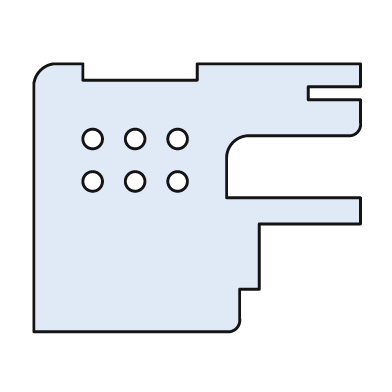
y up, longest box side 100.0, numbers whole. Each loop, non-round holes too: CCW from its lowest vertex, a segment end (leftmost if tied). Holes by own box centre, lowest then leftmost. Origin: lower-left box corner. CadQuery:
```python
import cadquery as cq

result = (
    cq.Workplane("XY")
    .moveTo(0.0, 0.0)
    .lineTo(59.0, 0.0)
    .threePointArc((62.0, 1.0), (63.0, 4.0))
    .lineTo(63.0, 13.0)
    .lineTo(69.0, 13.0)
    .lineTo(69.0, 33.0)
    .lineTo(100.0, 33.0)
    .lineTo(100.0, 41.0)
    .lineTo(59.0, 41.0)
    .lineTo(59.0, 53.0)
    .threePointArc((61.0, 58.0), (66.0, 60.0))
    .lineTo(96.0, 60.0)
    .threePointArc((99.0, 61.0), (100.0, 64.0))
    .lineTo(100.0, 71.0)
    .lineTo(84.0, 71.0)
    .lineTo(84.0, 75.0)
    .lineTo(100.0, 75.0)
    .lineTo(100.0, 82.0)
    .lineTo(50.0, 82.0)
    .lineTo(50.0, 77.0)
    .lineTo(15.0, 77.0)
    .lineTo(15.0, 82.0)
    .lineTo(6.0, 82.0)
    .threePointArc((2.0, 80.0), (0.0, 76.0))
    .close()
    .moveTo(18.0, 46.0)
    .circle(3.0)
    .moveTo(31.0, 46.0)
    .circle(3.0)
    .moveTo(44.0, 46.0)
    .circle(3.0)
    .moveTo(18.0, 59.0)
    .circle(3.0)
    .moveTo(31.0, 59.0)
    .circle(3.0)
    .moveTo(44.0, 59.0)
    .circle(3.0)
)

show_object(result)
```